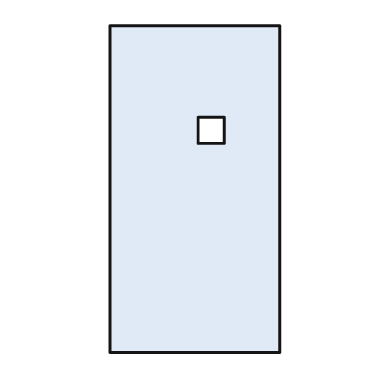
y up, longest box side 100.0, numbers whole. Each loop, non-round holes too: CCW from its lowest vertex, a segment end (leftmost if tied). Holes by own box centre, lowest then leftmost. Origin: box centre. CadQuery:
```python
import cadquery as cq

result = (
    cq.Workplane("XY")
    .moveTo(-26.0, -50.0)
    .lineTo(26.0, -50.0)
    .lineTo(26.0, 50.0)
    .lineTo(-26.0, 50.0)
    .close()
    .moveTo(1.0, 14.0)
    .lineTo(9.0, 14.0)
    .lineTo(9.0, 22.0)
    .lineTo(1.0, 22.0)
    .close()
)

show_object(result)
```